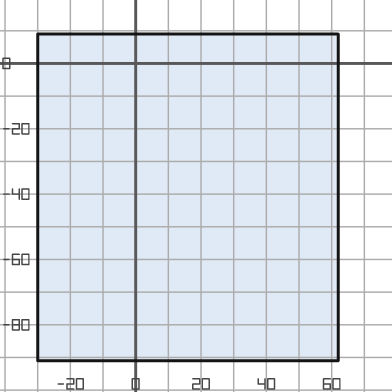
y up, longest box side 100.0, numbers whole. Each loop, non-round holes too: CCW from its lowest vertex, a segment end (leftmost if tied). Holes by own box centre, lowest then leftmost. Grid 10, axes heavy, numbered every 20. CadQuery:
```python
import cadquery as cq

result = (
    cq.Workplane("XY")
    .moveTo(-30.0, -91.0)
    .lineTo(62.0, -91.0)
    .lineTo(62.0, 9.0)
    .lineTo(-30.0, 9.0)
    .close()
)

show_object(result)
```